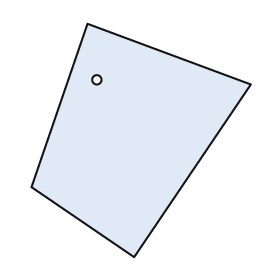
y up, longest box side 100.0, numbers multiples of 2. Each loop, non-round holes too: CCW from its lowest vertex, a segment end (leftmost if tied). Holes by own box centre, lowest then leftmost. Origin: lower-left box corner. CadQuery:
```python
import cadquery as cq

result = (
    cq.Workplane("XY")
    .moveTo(44.0, 0.0)
    .lineTo(94.0, 74.0)
    .lineTo(24.0, 100.0)
    .lineTo(0.0, 30.0)
    .close()
    .moveTo(28.0, 76.0)
    .circle(2.0)
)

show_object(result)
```